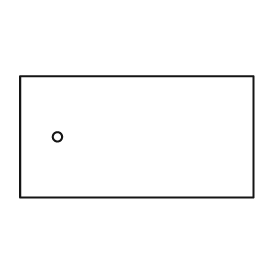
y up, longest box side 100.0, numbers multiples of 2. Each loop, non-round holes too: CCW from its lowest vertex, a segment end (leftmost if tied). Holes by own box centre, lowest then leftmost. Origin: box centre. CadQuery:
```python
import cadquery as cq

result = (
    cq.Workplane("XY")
    .moveTo(-50.0, -26.0)
    .lineTo(50.0, -26.0)
    .lineTo(50.0, 26.0)
    .lineTo(-50.0, 26.0)
    .close()
    .moveTo(-34.0, 0.0)
    .circle(2.0)
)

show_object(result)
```